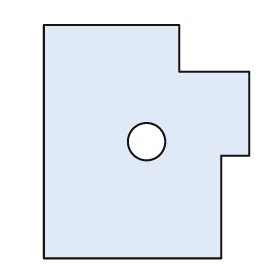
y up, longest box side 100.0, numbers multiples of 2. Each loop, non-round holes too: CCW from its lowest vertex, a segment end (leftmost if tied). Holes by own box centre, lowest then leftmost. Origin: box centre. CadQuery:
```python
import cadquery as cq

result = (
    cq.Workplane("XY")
    .moveTo(-44.0, -50.0)
    .lineTo(32.0, -50.0)
    .lineTo(32.0, -6.0)
    .lineTo(44.0, -6.0)
    .lineTo(44.0, 30.0)
    .lineTo(14.0, 30.0)
    .lineTo(14.0, 50.0)
    .lineTo(-44.0, 50.0)
    .close()
    .moveTo(0.0, 0.0)
    .circle(8.0)
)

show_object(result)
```